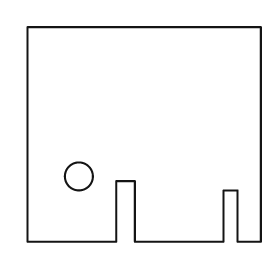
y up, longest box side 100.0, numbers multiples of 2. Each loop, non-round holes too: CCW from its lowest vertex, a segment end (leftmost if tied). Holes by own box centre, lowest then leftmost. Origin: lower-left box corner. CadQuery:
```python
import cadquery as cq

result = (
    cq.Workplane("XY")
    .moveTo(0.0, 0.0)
    .lineTo(38.0, 0.0)
    .lineTo(38.0, 26.0)
    .lineTo(46.0, 26.0)
    .lineTo(46.0, 0.0)
    .lineTo(84.0, 0.0)
    .lineTo(84.0, 22.0)
    .lineTo(90.0, 22.0)
    .lineTo(90.0, 0.0)
    .lineTo(100.0, 0.0)
    .lineTo(100.0, 92.0)
    .lineTo(0.0, 92.0)
    .close()
    .moveTo(22.0, 28.0)
    .circle(6.0)
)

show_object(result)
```